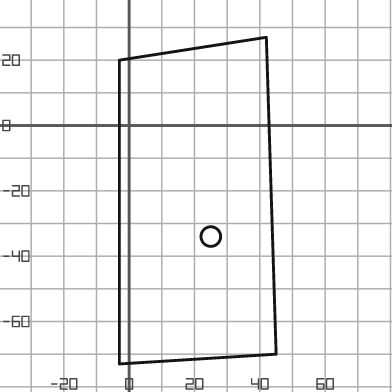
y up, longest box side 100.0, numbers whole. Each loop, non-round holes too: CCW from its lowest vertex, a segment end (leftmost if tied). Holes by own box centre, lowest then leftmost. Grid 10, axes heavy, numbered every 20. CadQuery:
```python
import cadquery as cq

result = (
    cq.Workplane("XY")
    .moveTo(-3.0, -73.0)
    .lineTo(45.0, -70.0)
    .lineTo(42.0, 27.0)
    .lineTo(-3.0, 20.0)
    .close()
    .moveTo(25.0, -34.0)
    .circle(3.0)
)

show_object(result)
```